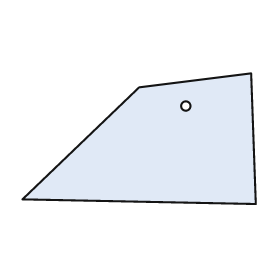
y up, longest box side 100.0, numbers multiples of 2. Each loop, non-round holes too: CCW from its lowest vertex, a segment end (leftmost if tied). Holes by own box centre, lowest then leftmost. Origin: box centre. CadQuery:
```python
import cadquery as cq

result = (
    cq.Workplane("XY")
    .moveTo(50.0, -28.0)
    .lineTo(48.0, 28.0)
    .lineTo(0.0, 22.0)
    .lineTo(-50.0, -26.0)
    .close()
    .moveTo(20.0, 14.0)
    .circle(2.0)
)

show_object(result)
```